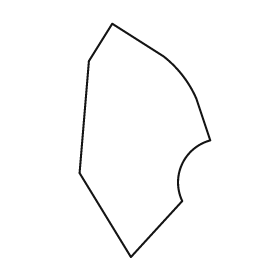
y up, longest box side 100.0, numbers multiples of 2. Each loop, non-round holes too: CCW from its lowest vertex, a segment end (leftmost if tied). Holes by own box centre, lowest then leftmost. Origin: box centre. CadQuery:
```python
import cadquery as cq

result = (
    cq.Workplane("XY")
    .moveTo(-6.0, -50.0)
    .lineTo(16.0, -26.0)
    .threePointArc((16.0, -10.0), (28.0, 0.0))
    .lineTo(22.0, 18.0)
    .threePointArc((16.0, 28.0), (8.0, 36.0))
    .lineTo(-14.0, 50.0)
    .lineTo(-24.0, 34.0)
    .lineTo(-28.0, -14.0)
    .close()
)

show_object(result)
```